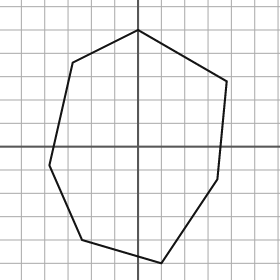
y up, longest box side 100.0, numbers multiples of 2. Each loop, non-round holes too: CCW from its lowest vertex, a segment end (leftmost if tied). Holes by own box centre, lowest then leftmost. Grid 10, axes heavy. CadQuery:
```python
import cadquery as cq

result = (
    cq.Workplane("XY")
    .moveTo(10.0, -50.0)
    .lineTo(34.0, -14.0)
    .lineTo(38.0, 28.0)
    .lineTo(0.0, 50.0)
    .lineTo(-28.0, 36.0)
    .lineTo(-38.0, -8.0)
    .lineTo(-24.0, -40.0)
    .close()
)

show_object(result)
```